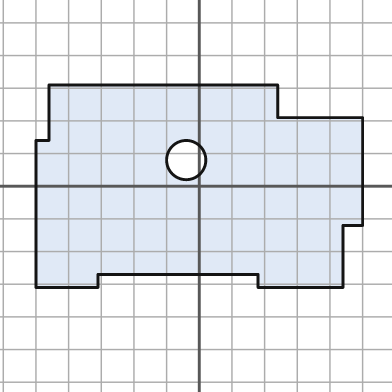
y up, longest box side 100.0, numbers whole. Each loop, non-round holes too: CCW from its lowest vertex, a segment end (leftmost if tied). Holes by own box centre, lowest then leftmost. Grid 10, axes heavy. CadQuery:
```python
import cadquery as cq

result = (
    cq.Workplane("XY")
    .moveTo(-50.0, -31.0)
    .lineTo(-31.0, -31.0)
    .lineTo(-31.0, -27.0)
    .lineTo(18.0, -27.0)
    .lineTo(18.0, -31.0)
    .lineTo(44.0, -31.0)
    .lineTo(44.0, -12.0)
    .lineTo(50.0, -12.0)
    .lineTo(50.0, 21.0)
    .lineTo(24.0, 21.0)
    .lineTo(24.0, 31.0)
    .lineTo(-46.0, 31.0)
    .lineTo(-46.0, 14.0)
    .lineTo(-50.0, 14.0)
    .close()
    .moveTo(-4.0, 8.0)
    .circle(6.0)
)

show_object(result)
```